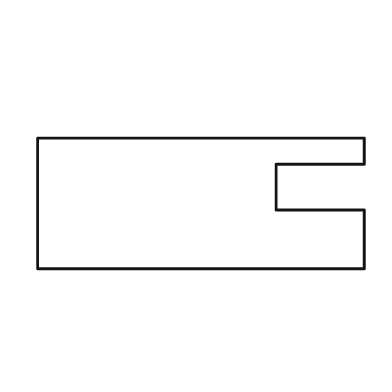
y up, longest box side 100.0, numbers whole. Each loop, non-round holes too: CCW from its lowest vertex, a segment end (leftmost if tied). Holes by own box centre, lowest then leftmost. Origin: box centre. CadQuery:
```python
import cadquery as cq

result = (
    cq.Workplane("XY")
    .moveTo(-50.0, -20.0)
    .lineTo(50.0, -20.0)
    .lineTo(50.0, -2.0)
    .lineTo(23.0, -2.0)
    .lineTo(23.0, 12.0)
    .lineTo(50.0, 12.0)
    .lineTo(50.0, 20.0)
    .lineTo(-50.0, 20.0)
    .close()
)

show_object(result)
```